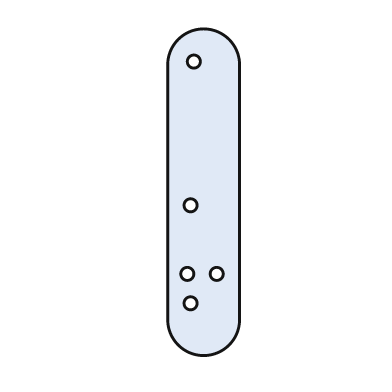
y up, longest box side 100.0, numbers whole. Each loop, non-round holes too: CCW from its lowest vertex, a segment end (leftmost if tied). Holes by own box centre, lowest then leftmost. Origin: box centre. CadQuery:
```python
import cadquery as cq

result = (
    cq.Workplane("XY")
    .moveTo(-11.0, -39.0)
    .threePointArc((0.0, -50.0), (11.0, -39.0))
    .lineTo(11.0, 39.0)
    .threePointArc((0.0, 50.0), (-11.0, 39.0))
    .close()
    .moveTo(-4.0, -34.0)
    .circle(2.0)
    .moveTo(-5.0, -25.0)
    .circle(2.0)
    .moveTo(4.0, -25.0)
    .circle(2.0)
    .moveTo(-4.0, -4.0)
    .circle(2.0)
    .moveTo(-3.0, 40.0)
    .circle(2.0)
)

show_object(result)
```